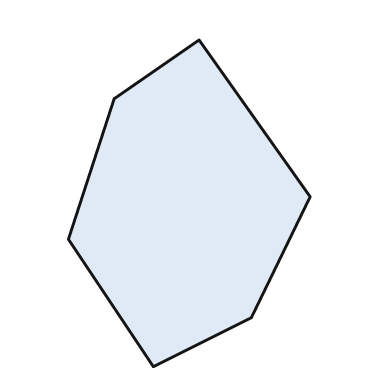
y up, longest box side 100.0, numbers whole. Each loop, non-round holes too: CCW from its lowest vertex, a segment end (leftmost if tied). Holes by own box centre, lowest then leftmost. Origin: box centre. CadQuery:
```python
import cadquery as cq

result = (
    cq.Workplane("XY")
    .moveTo(-11.0, -50.0)
    .lineTo(19.0, -35.0)
    .lineTo(37.0, 2.0)
    .lineTo(3.0, 50.0)
    .lineTo(-23.0, 32.0)
    .lineTo(-37.0, -11.0)
    .close()
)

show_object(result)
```